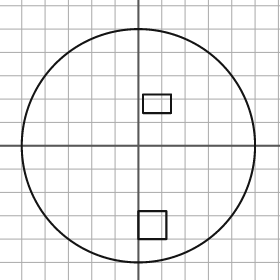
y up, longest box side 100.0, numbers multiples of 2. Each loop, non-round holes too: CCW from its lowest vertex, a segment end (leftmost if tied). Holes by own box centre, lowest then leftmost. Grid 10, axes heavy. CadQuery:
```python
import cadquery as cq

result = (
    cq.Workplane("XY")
    .moveTo(0.0, 0.0)
    .circle(50.0)
    .moveTo(0.0, -40.0)
    .lineTo(12.0, -40.0)
    .lineTo(12.0, -28.0)
    .lineTo(0.0, -28.0)
    .close()
    .moveTo(2.0, 14.0)
    .lineTo(14.0, 14.0)
    .lineTo(14.0, 22.0)
    .lineTo(2.0, 22.0)
    .close()
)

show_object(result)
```